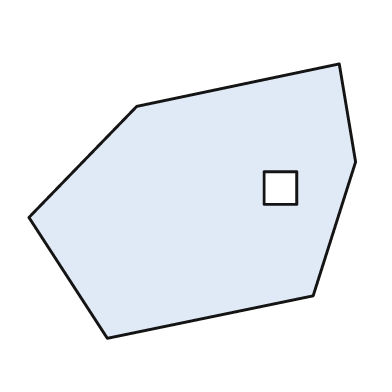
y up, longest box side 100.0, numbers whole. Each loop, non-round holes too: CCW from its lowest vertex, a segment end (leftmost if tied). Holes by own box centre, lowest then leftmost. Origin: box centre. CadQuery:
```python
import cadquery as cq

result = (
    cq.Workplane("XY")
    .moveTo(-26.0, -42.0)
    .lineTo(37.0, -29.0)
    .lineTo(50.0, 12.0)
    .lineTo(45.0, 42.0)
    .lineTo(-17.0, 29.0)
    .lineTo(-50.0, -5.0)
    .close()
    .moveTo(22.0, -1.0)
    .lineTo(32.0, -1.0)
    .lineTo(32.0, 9.0)
    .lineTo(22.0, 9.0)
    .close()
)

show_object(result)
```